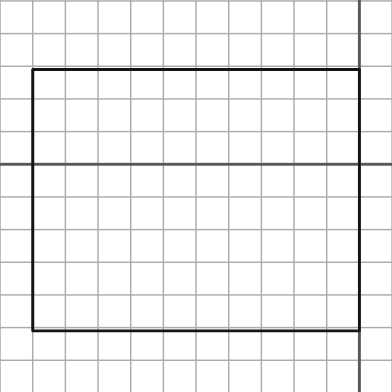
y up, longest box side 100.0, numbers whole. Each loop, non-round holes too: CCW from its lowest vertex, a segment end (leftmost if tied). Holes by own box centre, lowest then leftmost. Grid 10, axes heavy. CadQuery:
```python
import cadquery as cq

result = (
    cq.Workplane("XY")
    .moveTo(-100.0, -51.0)
    .lineTo(0.0, -51.0)
    .lineTo(0.0, 29.0)
    .lineTo(-100.0, 29.0)
    .close()
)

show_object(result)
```